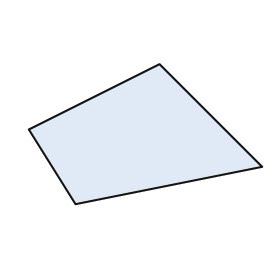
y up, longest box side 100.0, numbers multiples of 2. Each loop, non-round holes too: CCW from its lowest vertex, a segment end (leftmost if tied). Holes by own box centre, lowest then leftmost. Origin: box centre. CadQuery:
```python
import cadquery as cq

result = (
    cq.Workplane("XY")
    .moveTo(-30.0, -30.0)
    .lineTo(50.0, -14.0)
    .lineTo(6.0, 30.0)
    .lineTo(-50.0, 2.0)
    .close()
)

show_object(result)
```